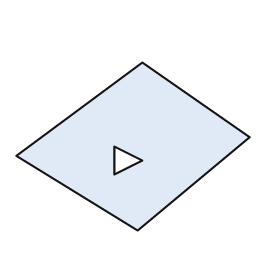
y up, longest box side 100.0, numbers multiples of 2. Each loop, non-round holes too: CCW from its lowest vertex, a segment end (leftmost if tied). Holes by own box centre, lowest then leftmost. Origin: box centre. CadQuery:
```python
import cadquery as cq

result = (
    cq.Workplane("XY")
    .moveTo(2.0, -36.0)
    .lineTo(50.0, 4.0)
    .lineTo(4.0, 36.0)
    .lineTo(-50.0, -4.0)
    .close()
    .moveTo(-8.0, -12.0)
    .lineTo(4.0, -6.0)
    .lineTo(-8.0, 0.0)
    .close()
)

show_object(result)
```